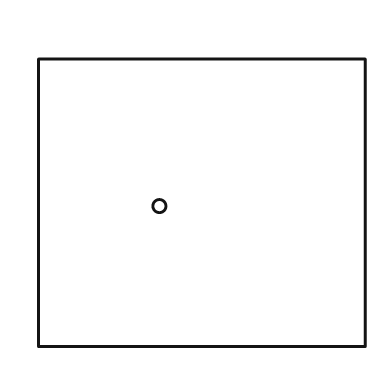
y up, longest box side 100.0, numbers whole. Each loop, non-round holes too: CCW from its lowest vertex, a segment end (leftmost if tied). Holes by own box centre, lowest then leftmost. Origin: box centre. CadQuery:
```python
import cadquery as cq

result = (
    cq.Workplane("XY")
    .moveTo(-50.0, -44.0)
    .lineTo(50.0, -44.0)
    .lineTo(50.0, 44.0)
    .lineTo(-50.0, 44.0)
    .close()
    .moveTo(-13.0, -1.0)
    .circle(2.0)
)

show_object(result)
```